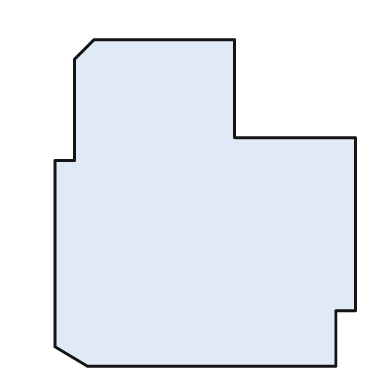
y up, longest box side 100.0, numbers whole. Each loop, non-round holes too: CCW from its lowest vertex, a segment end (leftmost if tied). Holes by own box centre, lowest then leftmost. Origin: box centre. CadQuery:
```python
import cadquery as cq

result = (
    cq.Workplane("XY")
    .moveTo(-36.0, -50.0)
    .lineTo(40.0, -50.0)
    .lineTo(40.0, -33.0)
    .lineTo(46.0, -33.0)
    .lineTo(46.0, 20.0)
    .lineTo(9.0, 20.0)
    .lineTo(9.0, 50.0)
    .lineTo(-34.0, 50.0)
    .lineTo(-40.0, 44.0)
    .lineTo(-40.0, 13.0)
    .lineTo(-46.0, 13.0)
    .lineTo(-46.0, -44.0)
    .close()
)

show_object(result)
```